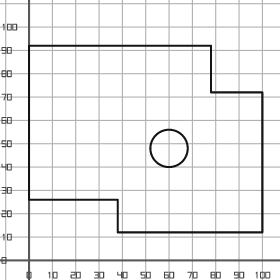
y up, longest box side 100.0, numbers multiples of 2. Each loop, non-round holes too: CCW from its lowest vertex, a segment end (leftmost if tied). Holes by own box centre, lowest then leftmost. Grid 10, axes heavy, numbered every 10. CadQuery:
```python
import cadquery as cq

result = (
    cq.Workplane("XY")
    .moveTo(38.0, 12.0)
    .lineTo(100.0, 12.0)
    .lineTo(100.0, 72.0)
    .lineTo(78.0, 72.0)
    .lineTo(78.0, 92.0)
    .lineTo(0.0, 92.0)
    .lineTo(0.0, 26.0)
    .lineTo(38.0, 26.0)
    .close()
    .moveTo(60.0, 48.0)
    .circle(8.0)
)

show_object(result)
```